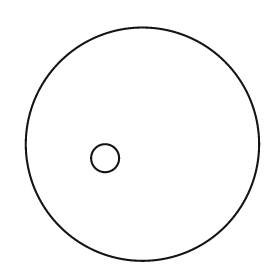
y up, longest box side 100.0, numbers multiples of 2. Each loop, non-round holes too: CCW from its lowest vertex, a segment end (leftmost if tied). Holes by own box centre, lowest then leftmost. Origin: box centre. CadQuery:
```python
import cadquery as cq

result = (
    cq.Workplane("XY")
    .moveTo(0.0, 0.0)
    .circle(50.0)
    .moveTo(-16.0, -6.0)
    .circle(6.0)
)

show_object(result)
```